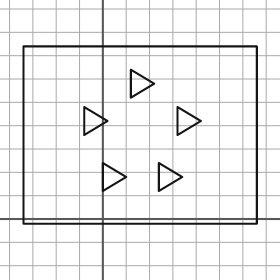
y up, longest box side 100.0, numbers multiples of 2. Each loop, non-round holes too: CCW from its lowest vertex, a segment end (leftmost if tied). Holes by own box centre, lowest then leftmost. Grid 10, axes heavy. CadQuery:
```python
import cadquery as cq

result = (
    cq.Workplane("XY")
    .moveTo(-34.0, -2.0)
    .lineTo(66.0, -2.0)
    .lineTo(66.0, 74.0)
    .lineTo(-34.0, 74.0)
    .close()
    .moveTo(0.0, 12.0)
    .lineTo(10.0, 18.0)
    .lineTo(0.0, 24.0)
    .close()
    .moveTo(24.0, 12.0)
    .lineTo(34.0, 18.0)
    .lineTo(24.0, 24.0)
    .close()
    .moveTo(-8.0, 36.0)
    .lineTo(2.0, 42.0)
    .lineTo(-8.0, 48.0)
    .close()
    .moveTo(32.0, 36.0)
    .lineTo(42.0, 42.0)
    .lineTo(32.0, 48.0)
    .close()
    .moveTo(12.0, 52.0)
    .lineTo(22.0, 58.0)
    .lineTo(12.0, 64.0)
    .close()
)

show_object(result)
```